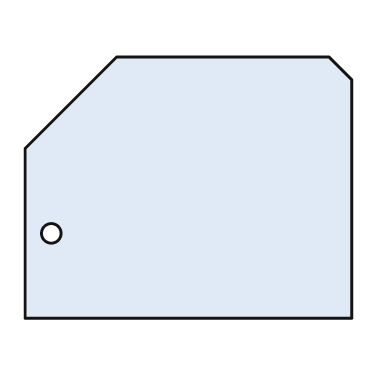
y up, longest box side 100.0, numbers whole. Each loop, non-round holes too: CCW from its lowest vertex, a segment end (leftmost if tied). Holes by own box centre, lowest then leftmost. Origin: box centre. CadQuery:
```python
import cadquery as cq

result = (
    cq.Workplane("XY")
    .moveTo(-50.0, -40.0)
    .lineTo(50.0, -40.0)
    .lineTo(50.0, 33.0)
    .lineTo(43.0, 40.0)
    .lineTo(-22.0, 40.0)
    .lineTo(-50.0, 12.0)
    .close()
    .moveTo(-42.0, -14.0)
    .circle(3.0)
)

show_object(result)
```